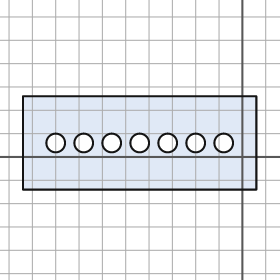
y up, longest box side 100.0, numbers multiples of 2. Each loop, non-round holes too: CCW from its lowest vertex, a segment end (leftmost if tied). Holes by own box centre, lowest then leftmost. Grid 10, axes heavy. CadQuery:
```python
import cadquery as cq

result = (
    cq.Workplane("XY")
    .moveTo(-94.0, -14.0)
    .lineTo(6.0, -14.0)
    .lineTo(6.0, 26.0)
    .lineTo(-94.0, 26.0)
    .close()
    .moveTo(-80.0, 6.0)
    .circle(4.0)
    .moveTo(-68.0, 6.0)
    .circle(4.0)
    .moveTo(-56.0, 6.0)
    .circle(4.0)
    .moveTo(-44.0, 6.0)
    .circle(4.0)
    .moveTo(-32.0, 6.0)
    .circle(4.0)
    .moveTo(-20.0, 6.0)
    .circle(4.0)
    .moveTo(-8.0, 6.0)
    .circle(4.0)
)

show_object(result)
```